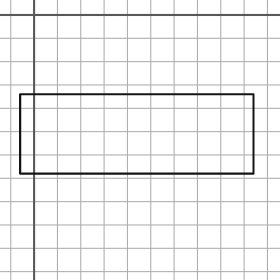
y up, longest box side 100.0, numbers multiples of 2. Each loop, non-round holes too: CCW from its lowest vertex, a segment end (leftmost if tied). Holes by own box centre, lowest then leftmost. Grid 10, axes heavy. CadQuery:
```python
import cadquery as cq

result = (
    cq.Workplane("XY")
    .moveTo(-6.0, -68.0)
    .lineTo(94.0, -68.0)
    .lineTo(94.0, -34.0)
    .lineTo(-6.0, -34.0)
    .close()
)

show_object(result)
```